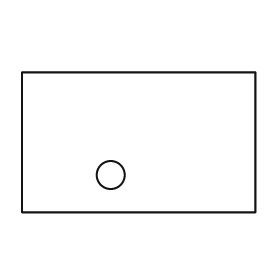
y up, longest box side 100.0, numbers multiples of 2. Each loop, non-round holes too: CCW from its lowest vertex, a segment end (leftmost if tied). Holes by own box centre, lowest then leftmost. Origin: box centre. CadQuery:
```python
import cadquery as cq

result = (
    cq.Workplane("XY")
    .moveTo(-50.0, -30.0)
    .lineTo(50.0, -30.0)
    .lineTo(50.0, 30.0)
    .lineTo(-50.0, 30.0)
    .close()
    .moveTo(-12.0, -14.0)
    .circle(6.0)
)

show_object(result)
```